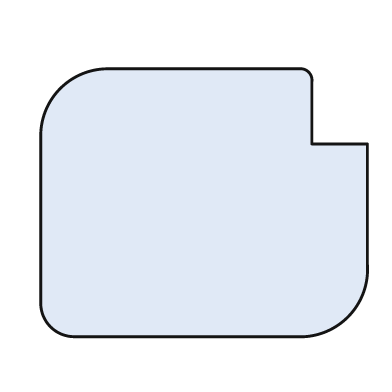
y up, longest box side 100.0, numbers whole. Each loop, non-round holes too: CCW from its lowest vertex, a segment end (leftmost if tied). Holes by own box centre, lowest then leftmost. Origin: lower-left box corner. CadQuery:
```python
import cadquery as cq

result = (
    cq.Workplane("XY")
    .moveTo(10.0, 0.0)
    .lineTo(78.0, 0.0)
    .threePointArc((94.0, 6.0), (100.0, 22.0))
    .lineTo(100.0, 59.0)
    .lineTo(83.0, 59.0)
    .lineTo(83.0, 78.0)
    .threePointArc((82.0, 81.0), (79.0, 82.0))
    .lineTo(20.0, 82.0)
    .threePointArc((6.0, 76.0), (0.0, 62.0))
    .lineTo(0.0, 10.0)
    .threePointArc((3.0, 3.0), (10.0, 0.0))
    .close()
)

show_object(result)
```